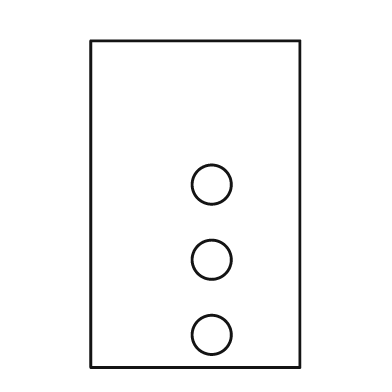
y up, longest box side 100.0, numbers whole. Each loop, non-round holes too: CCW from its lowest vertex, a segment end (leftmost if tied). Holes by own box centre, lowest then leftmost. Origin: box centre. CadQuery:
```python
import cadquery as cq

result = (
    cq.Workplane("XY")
    .moveTo(-32.0, -50.0)
    .lineTo(32.0, -50.0)
    .lineTo(32.0, 50.0)
    .lineTo(-32.0, 50.0)
    .close()
    .moveTo(5.0, -40.0)
    .circle(6.0)
    .moveTo(5.0, -17.0)
    .circle(6.0)
    .moveTo(5.0, 6.0)
    .circle(6.0)
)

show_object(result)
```